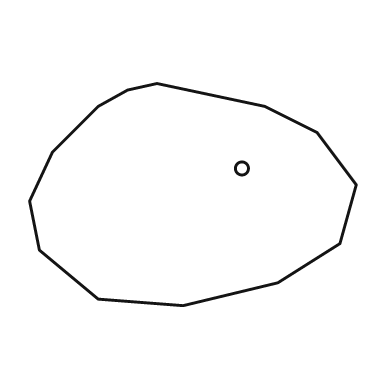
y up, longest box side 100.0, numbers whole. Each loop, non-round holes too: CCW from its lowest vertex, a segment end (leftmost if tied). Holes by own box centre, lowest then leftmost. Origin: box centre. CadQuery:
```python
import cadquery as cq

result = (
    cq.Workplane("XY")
    .moveTo(-3.0, -34.0)
    .lineTo(26.0, -27.0)
    .lineTo(45.0, -15.0)
    .lineTo(50.0, 3.0)
    .lineTo(38.0, 19.0)
    .lineTo(22.0, 27.0)
    .lineTo(-11.0, 34.0)
    .lineTo(-20.0, 32.0)
    .lineTo(-29.0, 27.0)
    .lineTo(-43.0, 13.0)
    .lineTo(-50.0, -2.0)
    .lineTo(-47.0, -17.0)
    .lineTo(-29.0, -32.0)
    .close()
    .moveTo(15.0, 8.0)
    .circle(2.0)
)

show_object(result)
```